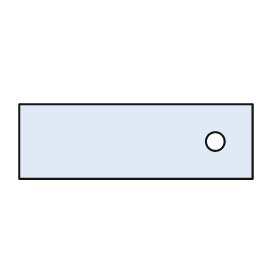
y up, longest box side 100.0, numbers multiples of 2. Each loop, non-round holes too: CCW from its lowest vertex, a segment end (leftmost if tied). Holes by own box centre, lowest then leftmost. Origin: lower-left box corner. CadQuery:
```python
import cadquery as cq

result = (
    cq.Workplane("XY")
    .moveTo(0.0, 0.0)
    .lineTo(100.0, 0.0)
    .lineTo(100.0, 32.0)
    .lineTo(0.0, 32.0)
    .close()
    .moveTo(84.0, 16.0)
    .circle(4.0)
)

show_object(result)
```